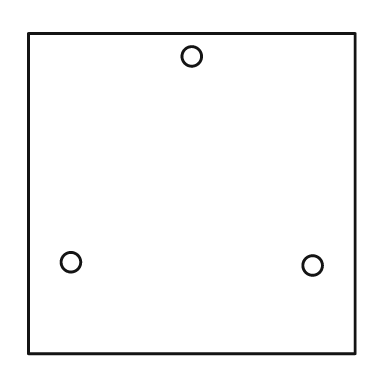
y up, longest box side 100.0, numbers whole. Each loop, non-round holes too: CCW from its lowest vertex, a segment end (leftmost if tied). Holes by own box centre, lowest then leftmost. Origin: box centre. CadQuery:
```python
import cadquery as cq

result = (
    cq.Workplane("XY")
    .moveTo(-50.0, -49.0)
    .lineTo(50.0, -49.0)
    .lineTo(50.0, 49.0)
    .lineTo(-50.0, 49.0)
    .close()
    .moveTo(37.0, -22.0)
    .circle(3.0)
    .moveTo(-37.0, -21.0)
    .circle(3.0)
    .moveTo(0.0, 42.0)
    .circle(3.0)
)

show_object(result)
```